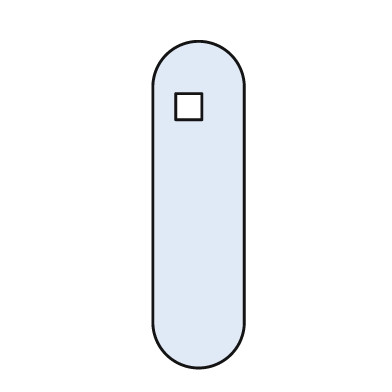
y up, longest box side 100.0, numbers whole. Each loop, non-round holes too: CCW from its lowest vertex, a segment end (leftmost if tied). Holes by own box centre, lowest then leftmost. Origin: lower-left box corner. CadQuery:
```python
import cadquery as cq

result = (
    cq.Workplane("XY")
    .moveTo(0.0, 14.0)
    .threePointArc((14.0, 0.0), (28.0, 14.0))
    .lineTo(28.0, 86.0)
    .threePointArc((14.0, 100.0), (0.0, 86.0))
    .close()
    .moveTo(7.0, 76.0)
    .lineTo(15.0, 76.0)
    .lineTo(15.0, 84.0)
    .lineTo(7.0, 84.0)
    .close()
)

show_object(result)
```